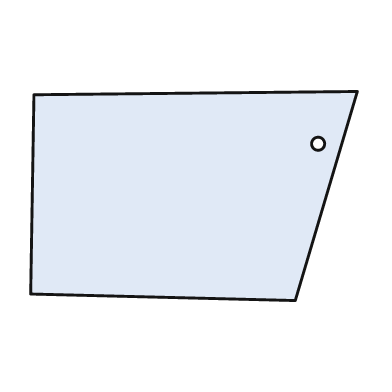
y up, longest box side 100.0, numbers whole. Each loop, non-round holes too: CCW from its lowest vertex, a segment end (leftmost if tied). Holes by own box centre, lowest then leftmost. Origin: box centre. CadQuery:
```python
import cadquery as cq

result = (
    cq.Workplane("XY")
    .moveTo(31.0, -32.0)
    .lineTo(50.0, 32.0)
    .lineTo(-49.0, 31.0)
    .lineTo(-50.0, -30.0)
    .close()
    .moveTo(38.0, 16.0)
    .circle(2.0)
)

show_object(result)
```